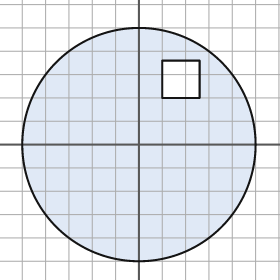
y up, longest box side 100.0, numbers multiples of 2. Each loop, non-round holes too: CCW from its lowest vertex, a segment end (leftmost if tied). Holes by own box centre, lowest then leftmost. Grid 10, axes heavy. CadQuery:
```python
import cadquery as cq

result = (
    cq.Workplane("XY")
    .moveTo(0.0, 0.0)
    .circle(50.0)
    .moveTo(10.0, 20.0)
    .lineTo(26.0, 20.0)
    .lineTo(26.0, 36.0)
    .lineTo(10.0, 36.0)
    .close()
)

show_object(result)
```